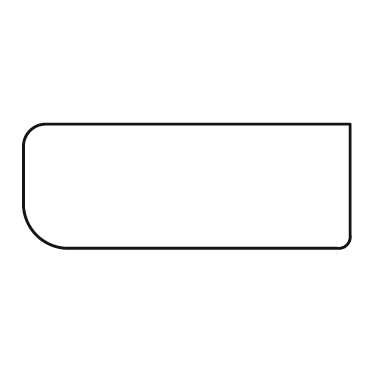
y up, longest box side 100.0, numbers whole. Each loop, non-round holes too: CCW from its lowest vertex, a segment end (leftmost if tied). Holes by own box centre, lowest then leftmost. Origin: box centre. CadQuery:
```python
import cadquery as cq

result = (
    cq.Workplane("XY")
    .moveTo(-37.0, -19.0)
    .lineTo(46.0, -19.0)
    .threePointArc((49.0, -18.0), (50.0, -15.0))
    .lineTo(50.0, 19.0)
    .lineTo(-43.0, 19.0)
    .threePointArc((-48.0, 17.0), (-50.0, 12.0))
    .lineTo(-50.0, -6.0)
    .threePointArc((-46.0, -15.0), (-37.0, -19.0))
    .close()
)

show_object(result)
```